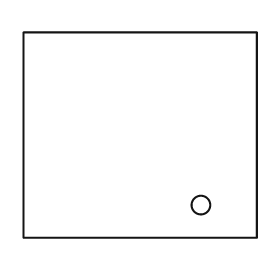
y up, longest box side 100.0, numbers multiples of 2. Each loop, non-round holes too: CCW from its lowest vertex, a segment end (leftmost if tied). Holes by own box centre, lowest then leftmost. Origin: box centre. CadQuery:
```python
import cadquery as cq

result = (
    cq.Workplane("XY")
    .moveTo(-50.0, -44.0)
    .lineTo(50.0, -44.0)
    .lineTo(50.0, 44.0)
    .lineTo(-50.0, 44.0)
    .close()
    .moveTo(26.0, -30.0)
    .circle(4.0)
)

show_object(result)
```